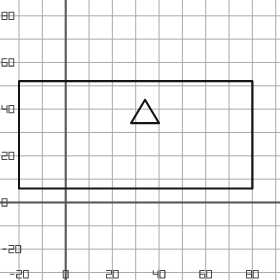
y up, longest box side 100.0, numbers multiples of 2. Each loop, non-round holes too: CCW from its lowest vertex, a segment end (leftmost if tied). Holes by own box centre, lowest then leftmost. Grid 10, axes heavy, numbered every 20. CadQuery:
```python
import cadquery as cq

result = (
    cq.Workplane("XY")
    .moveTo(-20.0, 6.0)
    .lineTo(80.0, 6.0)
    .lineTo(80.0, 52.0)
    .lineTo(-20.0, 52.0)
    .close()
    .moveTo(28.0, 34.0)
    .lineTo(40.0, 34.0)
    .lineTo(34.0, 44.0)
    .close()
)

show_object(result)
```